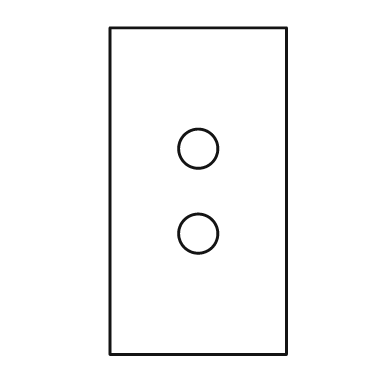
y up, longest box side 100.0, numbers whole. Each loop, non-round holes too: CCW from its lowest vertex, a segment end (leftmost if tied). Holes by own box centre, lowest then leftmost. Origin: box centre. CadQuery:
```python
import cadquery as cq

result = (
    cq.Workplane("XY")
    .moveTo(-27.0, -50.0)
    .lineTo(27.0, -50.0)
    .lineTo(27.0, 50.0)
    .lineTo(-27.0, 50.0)
    .close()
    .moveTo(0.0, -13.0)
    .circle(6.0)
    .moveTo(0.0, 13.0)
    .circle(6.0)
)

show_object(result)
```